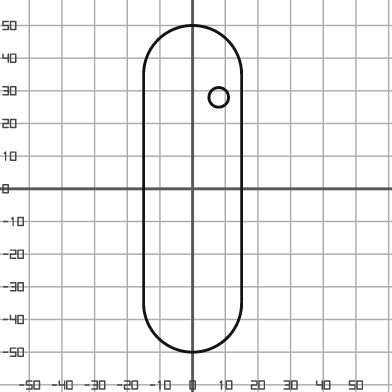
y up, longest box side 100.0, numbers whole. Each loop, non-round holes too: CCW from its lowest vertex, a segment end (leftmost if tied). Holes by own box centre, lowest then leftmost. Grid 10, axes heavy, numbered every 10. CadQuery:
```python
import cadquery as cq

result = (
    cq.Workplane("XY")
    .moveTo(-15.0, -35.0)
    .threePointArc((0.0, -50.0), (15.0, -35.0))
    .lineTo(15.0, 35.0)
    .threePointArc((0.0, 50.0), (-15.0, 35.0))
    .close()
    .moveTo(8.0, 28.0)
    .circle(3.0)
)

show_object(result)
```